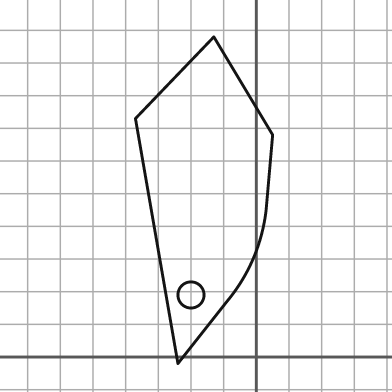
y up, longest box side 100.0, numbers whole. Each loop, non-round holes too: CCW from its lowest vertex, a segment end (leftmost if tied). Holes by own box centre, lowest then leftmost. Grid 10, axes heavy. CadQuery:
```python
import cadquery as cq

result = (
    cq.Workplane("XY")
    .moveTo(-24.0, -2.0)
    .lineTo(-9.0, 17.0)
    .threePointArc((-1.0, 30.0), (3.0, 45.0))
    .lineTo(5.0, 68.0)
    .lineTo(-13.0, 98.0)
    .lineTo(-37.0, 73.0)
    .close()
    .moveTo(-20.0, 19.0)
    .circle(4.0)
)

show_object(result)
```